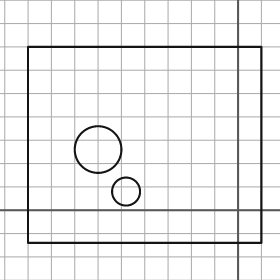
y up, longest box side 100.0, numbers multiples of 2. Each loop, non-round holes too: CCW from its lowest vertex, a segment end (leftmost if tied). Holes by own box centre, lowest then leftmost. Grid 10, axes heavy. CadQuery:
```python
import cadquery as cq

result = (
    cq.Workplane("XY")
    .moveTo(-90.0, -14.0)
    .lineTo(10.0, -14.0)
    .lineTo(10.0, 70.0)
    .lineTo(-90.0, 70.0)
    .close()
    .moveTo(-48.0, 8.0)
    .circle(6.0)
    .moveTo(-60.0, 26.0)
    .circle(10.0)
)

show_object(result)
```